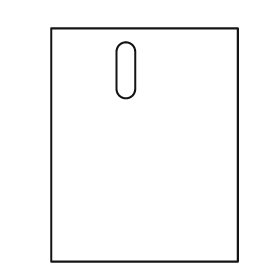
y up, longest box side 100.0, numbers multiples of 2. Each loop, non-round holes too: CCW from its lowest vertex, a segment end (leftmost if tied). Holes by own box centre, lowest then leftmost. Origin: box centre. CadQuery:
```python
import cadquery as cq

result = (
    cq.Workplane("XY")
    .moveTo(-40.0, -50.0)
    .lineTo(40.0, -50.0)
    .lineTo(40.0, 50.0)
    .lineTo(-40.0, 50.0)
    .close()
    .moveTo(-12.0, 24.0)
    .threePointArc((-8.0, 20.0), (-4.0, 24.0))
    .lineTo(-4.0, 40.0)
    .threePointArc((-8.0, 44.0), (-12.0, 40.0))
    .close()
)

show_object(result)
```